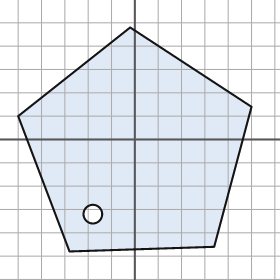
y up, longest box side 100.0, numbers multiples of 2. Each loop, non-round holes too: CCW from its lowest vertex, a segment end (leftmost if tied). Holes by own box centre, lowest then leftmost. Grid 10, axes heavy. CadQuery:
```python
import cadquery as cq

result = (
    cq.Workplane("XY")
    .moveTo(-28.0, -48.0)
    .lineTo(34.0, -46.0)
    .lineTo(50.0, 14.0)
    .lineTo(-2.0, 48.0)
    .lineTo(-50.0, 10.0)
    .close()
    .moveTo(-18.0, -32.0)
    .circle(4.0)
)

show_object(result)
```